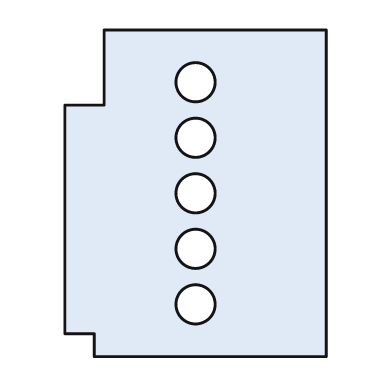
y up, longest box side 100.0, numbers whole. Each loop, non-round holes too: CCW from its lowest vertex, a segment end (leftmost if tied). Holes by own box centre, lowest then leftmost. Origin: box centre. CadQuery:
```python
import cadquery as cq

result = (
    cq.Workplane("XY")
    .moveTo(-31.0, -50.0)
    .lineTo(40.0, -50.0)
    .lineTo(40.0, 50.0)
    .lineTo(-28.0, 50.0)
    .lineTo(-28.0, 27.0)
    .lineTo(-40.0, 27.0)
    .lineTo(-40.0, -43.0)
    .lineTo(-31.0, -43.0)
    .close()
    .moveTo(0.0, -34.0)
    .circle(6.0)
    .moveTo(0.0, -17.0)
    .circle(6.0)
    .moveTo(0.0, 0.0)
    .circle(6.0)
    .moveTo(0.0, 17.0)
    .circle(6.0)
    .moveTo(0.0, 34.0)
    .circle(6.0)
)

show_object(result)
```